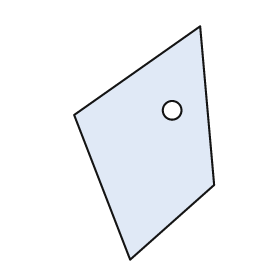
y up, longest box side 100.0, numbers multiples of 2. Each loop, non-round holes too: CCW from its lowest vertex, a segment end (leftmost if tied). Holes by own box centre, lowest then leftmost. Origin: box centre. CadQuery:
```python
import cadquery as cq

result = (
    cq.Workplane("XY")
    .moveTo(-6.0, -50.0)
    .lineTo(30.0, -18.0)
    .lineTo(24.0, 50.0)
    .lineTo(-30.0, 12.0)
    .close()
    .moveTo(12.0, 14.0)
    .circle(4.0)
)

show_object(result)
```